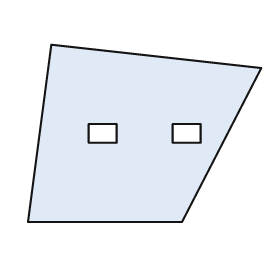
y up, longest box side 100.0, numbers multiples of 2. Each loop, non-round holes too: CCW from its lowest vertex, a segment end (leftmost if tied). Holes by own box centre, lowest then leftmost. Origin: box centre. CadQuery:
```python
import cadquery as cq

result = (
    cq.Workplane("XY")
    .moveTo(-50.0, -38.0)
    .lineTo(16.0, -38.0)
    .lineTo(50.0, 28.0)
    .lineTo(-40.0, 38.0)
    .close()
    .moveTo(-24.0, -4.0)
    .lineTo(-12.0, -4.0)
    .lineTo(-12.0, 4.0)
    .lineTo(-24.0, 4.0)
    .close()
    .moveTo(12.0, -4.0)
    .lineTo(24.0, -4.0)
    .lineTo(24.0, 4.0)
    .lineTo(12.0, 4.0)
    .close()
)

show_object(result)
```